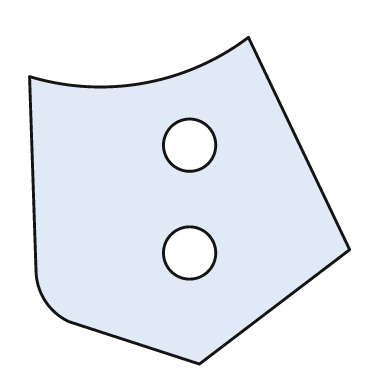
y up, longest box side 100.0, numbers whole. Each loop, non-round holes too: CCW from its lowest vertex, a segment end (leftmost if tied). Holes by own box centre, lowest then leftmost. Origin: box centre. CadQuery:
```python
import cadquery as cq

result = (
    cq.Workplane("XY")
    .moveTo(3.0, -50.0)
    .lineTo(49.0, -15.0)
    .lineTo(18.0, 50.0)
    .threePointArc((-14.0, 36.0), (-49.0, 38.0))
    .lineTo(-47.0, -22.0)
    .threePointArc((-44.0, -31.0), (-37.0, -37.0))
    .close()
    .moveTo(0.0, -16.0)
    .circle(8.0)
    .moveTo(0.0, 17.0)
    .circle(8.0)
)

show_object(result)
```